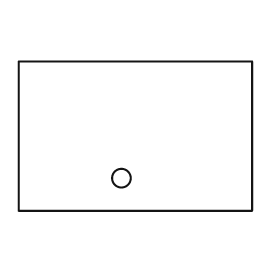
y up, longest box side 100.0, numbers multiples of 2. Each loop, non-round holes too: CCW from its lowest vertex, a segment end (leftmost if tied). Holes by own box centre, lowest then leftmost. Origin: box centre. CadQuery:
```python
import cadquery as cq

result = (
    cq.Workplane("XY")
    .moveTo(-50.0, -32.0)
    .lineTo(50.0, -32.0)
    .lineTo(50.0, 32.0)
    .lineTo(-50.0, 32.0)
    .close()
    .moveTo(-6.0, -18.0)
    .circle(4.0)
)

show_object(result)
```